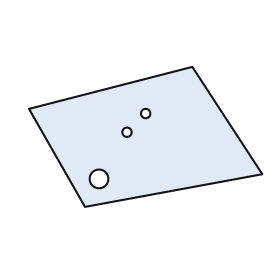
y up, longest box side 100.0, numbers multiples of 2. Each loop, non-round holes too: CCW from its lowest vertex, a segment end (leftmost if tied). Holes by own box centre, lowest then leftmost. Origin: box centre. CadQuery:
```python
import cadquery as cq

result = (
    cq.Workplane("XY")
    .moveTo(-26.0, -30.0)
    .lineTo(50.0, -16.0)
    .lineTo(20.0, 30.0)
    .lineTo(-50.0, 12.0)
    .close()
    .moveTo(-20.0, -18.0)
    .circle(4.0)
    .moveTo(-8.0, 2.0)
    .circle(2.0)
    .moveTo(0.0, 10.0)
    .circle(2.0)
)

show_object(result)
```